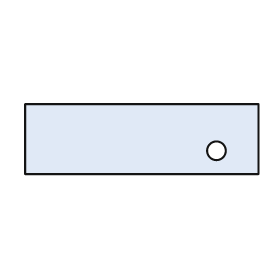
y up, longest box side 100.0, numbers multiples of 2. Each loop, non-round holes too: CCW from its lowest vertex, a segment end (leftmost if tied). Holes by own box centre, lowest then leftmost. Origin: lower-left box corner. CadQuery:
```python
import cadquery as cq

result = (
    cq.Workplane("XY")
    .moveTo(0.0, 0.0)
    .lineTo(100.0, 0.0)
    .lineTo(100.0, 30.0)
    .lineTo(0.0, 30.0)
    .close()
    .moveTo(82.0, 10.0)
    .circle(4.0)
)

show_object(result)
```